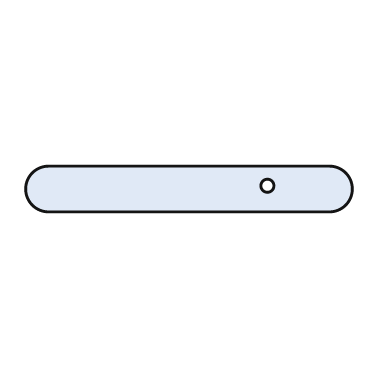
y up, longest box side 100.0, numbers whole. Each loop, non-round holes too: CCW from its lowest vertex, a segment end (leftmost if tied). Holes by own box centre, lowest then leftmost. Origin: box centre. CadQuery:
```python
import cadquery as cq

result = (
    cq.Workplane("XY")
    .moveTo(-43.0, -7.0)
    .lineTo(43.0, -7.0)
    .threePointArc((50.0, 0.0), (43.0, 7.0))
    .lineTo(-43.0, 7.0)
    .threePointArc((-50.0, 0.0), (-43.0, -7.0))
    .close()
    .moveTo(24.0, 1.0)
    .circle(2.0)
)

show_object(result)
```